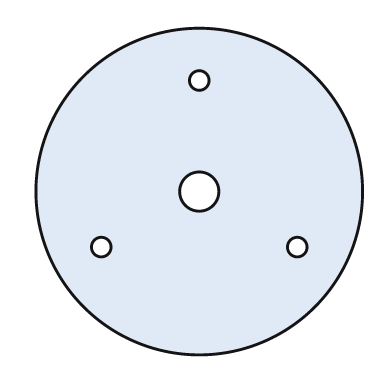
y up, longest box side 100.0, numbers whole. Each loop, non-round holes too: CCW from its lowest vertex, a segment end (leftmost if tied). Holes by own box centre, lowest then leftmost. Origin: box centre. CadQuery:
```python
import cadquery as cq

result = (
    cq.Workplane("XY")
    .moveTo(0.0, 0.0)
    .circle(50.0)
    .moveTo(-30.0, -17.0)
    .circle(3.0)
    .moveTo(30.0, -17.0)
    .circle(3.0)
    .moveTo(0.0, 0.0)
    .circle(6.0)
    .moveTo(0.0, 34.0)
    .circle(3.0)
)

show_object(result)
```